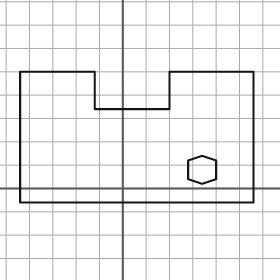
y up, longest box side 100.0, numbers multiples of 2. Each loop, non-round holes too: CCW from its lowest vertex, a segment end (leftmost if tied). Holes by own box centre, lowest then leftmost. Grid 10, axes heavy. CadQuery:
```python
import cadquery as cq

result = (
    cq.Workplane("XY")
    .moveTo(-44.0, -6.0)
    .lineTo(56.0, -6.0)
    .lineTo(56.0, 50.0)
    .lineTo(20.0, 50.0)
    .lineTo(20.0, 34.0)
    .lineTo(-12.0, 34.0)
    .lineTo(-12.0, 50.0)
    .lineTo(-44.0, 50.0)
    .close()
    .moveTo(34.0, 2.0)
    .lineTo(40.0, 4.0)
    .lineTo(40.0, 12.0)
    .lineTo(34.0, 14.0)
    .lineTo(28.0, 12.0)
    .lineTo(28.0, 4.0)
    .close()
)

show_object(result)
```